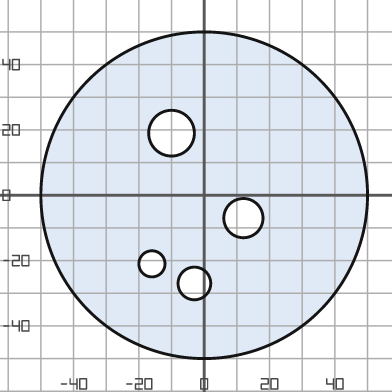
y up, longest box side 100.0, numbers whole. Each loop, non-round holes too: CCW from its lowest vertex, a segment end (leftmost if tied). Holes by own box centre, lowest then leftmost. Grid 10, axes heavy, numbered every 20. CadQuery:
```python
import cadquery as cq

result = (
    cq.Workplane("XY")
    .moveTo(0.0, 0.0)
    .circle(50.0)
    .moveTo(-3.0, -27.0)
    .circle(5.0)
    .moveTo(-16.0, -21.0)
    .circle(4.0)
    .moveTo(12.0, -7.0)
    .circle(6.0)
    .moveTo(-10.0, 19.0)
    .circle(7.0)
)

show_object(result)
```